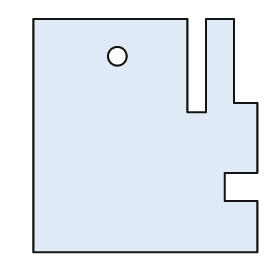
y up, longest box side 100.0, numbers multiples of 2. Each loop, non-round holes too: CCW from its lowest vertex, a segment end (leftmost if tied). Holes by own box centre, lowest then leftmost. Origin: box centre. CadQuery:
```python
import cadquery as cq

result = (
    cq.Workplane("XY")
    .moveTo(-48.0, -50.0)
    .lineTo(48.0, -50.0)
    .lineTo(48.0, -28.0)
    .lineTo(34.0, -28.0)
    .lineTo(34.0, -16.0)
    .lineTo(48.0, -16.0)
    .lineTo(48.0, 14.0)
    .lineTo(38.0, 14.0)
    .lineTo(38.0, 50.0)
    .lineTo(26.0, 50.0)
    .lineTo(26.0, 10.0)
    .lineTo(18.0, 10.0)
    .lineTo(18.0, 50.0)
    .lineTo(-48.0, 50.0)
    .close()
    .moveTo(-12.0, 34.0)
    .circle(4.0)
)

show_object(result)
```